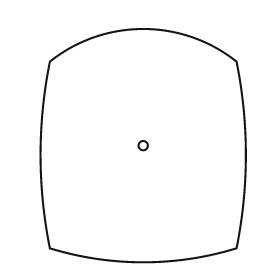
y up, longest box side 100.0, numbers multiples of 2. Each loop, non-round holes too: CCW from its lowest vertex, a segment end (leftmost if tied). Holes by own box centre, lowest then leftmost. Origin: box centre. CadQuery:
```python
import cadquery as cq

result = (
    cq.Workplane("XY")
    .moveTo(-40.0, -44.0)
    .threePointArc((0.0, -50.0), (40.0, -44.0))
    .threePointArc((44.0, -4.0), (40.0, 36.0))
    .threePointArc((0.0, 50.0), (-40.0, 36.0))
    .threePointArc((-44.0, -4.0), (-40.0, -44.0))
    .close()
    .moveTo(0.0, 0.0)
    .circle(2.0)
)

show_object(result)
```